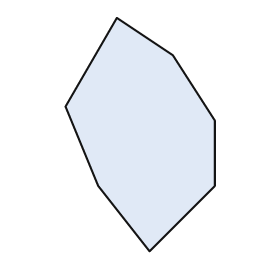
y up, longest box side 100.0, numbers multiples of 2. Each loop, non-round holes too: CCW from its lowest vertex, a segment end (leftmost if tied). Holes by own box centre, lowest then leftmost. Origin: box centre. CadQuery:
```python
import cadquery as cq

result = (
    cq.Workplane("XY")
    .moveTo(4.0, -50.0)
    .lineTo(32.0, -22.0)
    .lineTo(32.0, 6.0)
    .lineTo(14.0, 34.0)
    .lineTo(-10.0, 50.0)
    .lineTo(-32.0, 12.0)
    .lineTo(-18.0, -22.0)
    .close()
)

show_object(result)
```